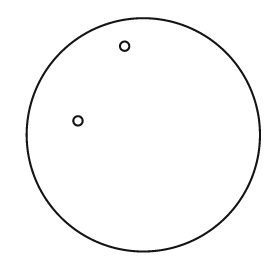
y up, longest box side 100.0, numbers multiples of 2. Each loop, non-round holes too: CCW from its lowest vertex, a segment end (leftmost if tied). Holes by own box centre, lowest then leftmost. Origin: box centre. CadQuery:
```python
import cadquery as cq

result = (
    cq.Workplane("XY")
    .moveTo(0.0, 0.0)
    .circle(50.0)
    .moveTo(-28.0, 6.0)
    .circle(2.0)
    .moveTo(-8.0, 38.0)
    .circle(2.0)
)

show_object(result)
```